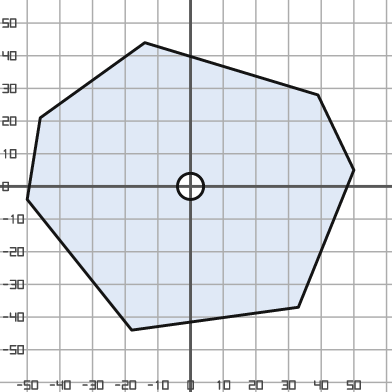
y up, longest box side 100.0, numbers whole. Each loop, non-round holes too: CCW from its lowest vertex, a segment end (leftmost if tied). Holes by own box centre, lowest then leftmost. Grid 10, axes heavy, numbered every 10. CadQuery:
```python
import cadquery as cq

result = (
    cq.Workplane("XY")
    .moveTo(-18.0, -44.0)
    .lineTo(33.0, -37.0)
    .lineTo(50.0, 5.0)
    .lineTo(39.0, 28.0)
    .lineTo(-14.0, 44.0)
    .lineTo(-46.0, 21.0)
    .lineTo(-50.0, -4.0)
    .close()
    .moveTo(0.0, 0.0)
    .circle(4.0)
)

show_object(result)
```